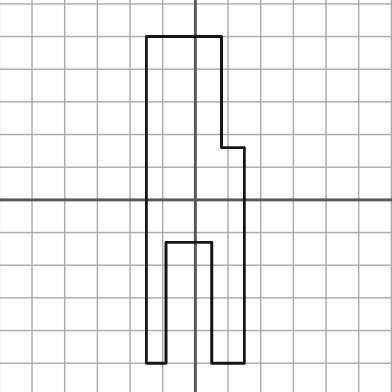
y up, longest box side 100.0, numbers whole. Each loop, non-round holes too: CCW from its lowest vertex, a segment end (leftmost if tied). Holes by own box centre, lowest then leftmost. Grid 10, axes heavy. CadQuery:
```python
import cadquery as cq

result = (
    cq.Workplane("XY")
    .moveTo(-15.0, -50.0)
    .lineTo(-9.0, -50.0)
    .lineTo(-9.0, -13.0)
    .lineTo(5.0, -13.0)
    .lineTo(5.0, -50.0)
    .lineTo(15.0, -50.0)
    .lineTo(15.0, 16.0)
    .lineTo(8.0, 16.0)
    .lineTo(8.0, 50.0)
    .lineTo(-15.0, 50.0)
    .close()
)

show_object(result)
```